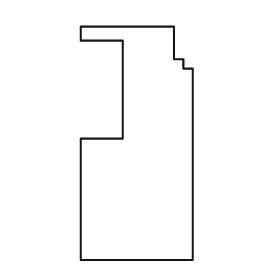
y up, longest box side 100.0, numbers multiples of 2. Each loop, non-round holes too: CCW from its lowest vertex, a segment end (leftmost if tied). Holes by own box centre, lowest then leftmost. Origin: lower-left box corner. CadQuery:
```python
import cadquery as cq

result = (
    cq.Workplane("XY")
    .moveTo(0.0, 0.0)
    .lineTo(48.0, 0.0)
    .lineTo(48.0, 82.0)
    .lineTo(44.0, 82.0)
    .lineTo(44.0, 86.0)
    .lineTo(40.0, 86.0)
    .lineTo(40.0, 100.0)
    .lineTo(0.0, 100.0)
    .lineTo(0.0, 94.0)
    .lineTo(18.0, 94.0)
    .lineTo(18.0, 52.0)
    .lineTo(0.0, 52.0)
    .close()
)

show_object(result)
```